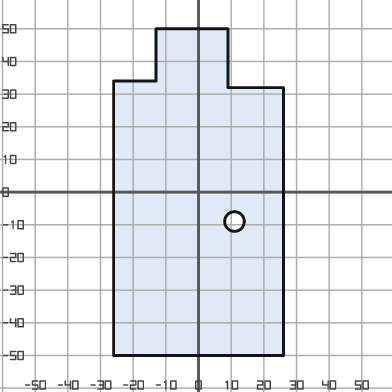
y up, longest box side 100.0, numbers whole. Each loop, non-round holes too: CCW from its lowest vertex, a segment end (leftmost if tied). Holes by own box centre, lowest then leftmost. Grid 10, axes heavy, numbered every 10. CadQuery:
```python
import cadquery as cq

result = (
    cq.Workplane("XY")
    .moveTo(-26.0, -50.0)
    .lineTo(26.0, -50.0)
    .lineTo(26.0, 32.0)
    .lineTo(9.0, 32.0)
    .lineTo(9.0, 50.0)
    .lineTo(-13.0, 50.0)
    .lineTo(-13.0, 34.0)
    .lineTo(-26.0, 34.0)
    .close()
    .moveTo(11.0, -9.0)
    .circle(3.0)
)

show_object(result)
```